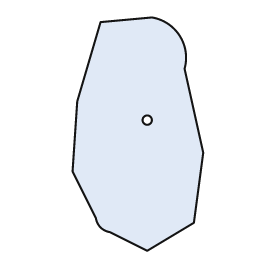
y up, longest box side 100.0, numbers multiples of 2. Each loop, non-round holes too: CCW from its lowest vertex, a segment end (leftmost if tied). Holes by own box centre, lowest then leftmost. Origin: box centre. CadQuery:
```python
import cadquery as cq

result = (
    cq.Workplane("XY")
    .moveTo(4.0, -50.0)
    .lineTo(24.0, -38.0)
    .lineTo(28.0, -8.0)
    .lineTo(20.0, 28.0)
    .threePointArc((18.0, 42.0), (6.0, 50.0))
    .lineTo(-16.0, 48.0)
    .lineTo(-26.0, 14.0)
    .lineTo(-28.0, -16.0)
    .lineTo(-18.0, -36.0)
    .threePointArc((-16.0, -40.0), (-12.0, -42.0))
    .close()
    .moveTo(4.0, 6.0)
    .circle(2.0)
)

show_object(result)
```